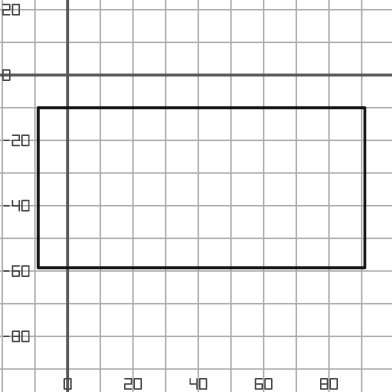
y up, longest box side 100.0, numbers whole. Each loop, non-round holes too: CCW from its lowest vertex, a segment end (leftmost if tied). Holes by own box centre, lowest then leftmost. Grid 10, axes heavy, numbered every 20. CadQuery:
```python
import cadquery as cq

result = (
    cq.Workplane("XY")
    .moveTo(-9.0, -59.0)
    .lineTo(91.0, -59.0)
    .lineTo(91.0, -10.0)
    .lineTo(-9.0, -10.0)
    .close()
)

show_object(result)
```